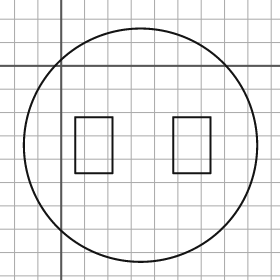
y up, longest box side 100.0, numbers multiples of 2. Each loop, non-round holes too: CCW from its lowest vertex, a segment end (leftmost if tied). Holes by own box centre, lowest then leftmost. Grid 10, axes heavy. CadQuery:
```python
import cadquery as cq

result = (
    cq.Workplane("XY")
    .moveTo(34.0, -34.0)
    .circle(50.0)
    .moveTo(6.0, -46.0)
    .lineTo(22.0, -46.0)
    .lineTo(22.0, -22.0)
    .lineTo(6.0, -22.0)
    .close()
    .moveTo(48.0, -46.0)
    .lineTo(64.0, -46.0)
    .lineTo(64.0, -22.0)
    .lineTo(48.0, -22.0)
    .close()
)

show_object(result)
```